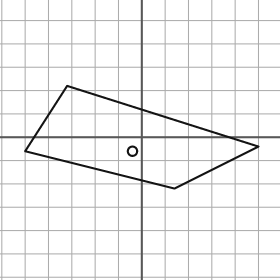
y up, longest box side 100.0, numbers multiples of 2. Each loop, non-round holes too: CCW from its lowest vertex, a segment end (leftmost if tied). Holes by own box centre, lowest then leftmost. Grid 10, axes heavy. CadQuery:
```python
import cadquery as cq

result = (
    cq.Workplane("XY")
    .moveTo(14.0, -22.0)
    .lineTo(50.0, -4.0)
    .lineTo(-32.0, 22.0)
    .lineTo(-50.0, -6.0)
    .close()
    .moveTo(-4.0, -6.0)
    .circle(2.0)
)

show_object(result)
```